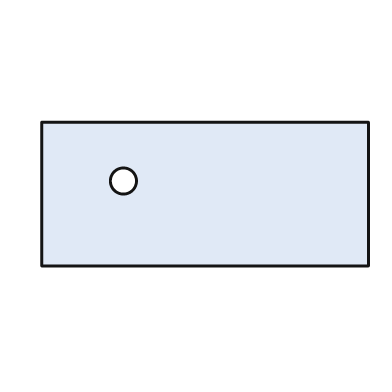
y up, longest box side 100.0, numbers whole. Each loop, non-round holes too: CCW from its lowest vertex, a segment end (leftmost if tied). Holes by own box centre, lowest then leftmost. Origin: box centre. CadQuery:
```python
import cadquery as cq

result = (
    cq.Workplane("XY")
    .moveTo(-50.0, -22.0)
    .lineTo(50.0, -22.0)
    .lineTo(50.0, 22.0)
    .lineTo(-50.0, 22.0)
    .close()
    .moveTo(-25.0, 4.0)
    .circle(4.0)
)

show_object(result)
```